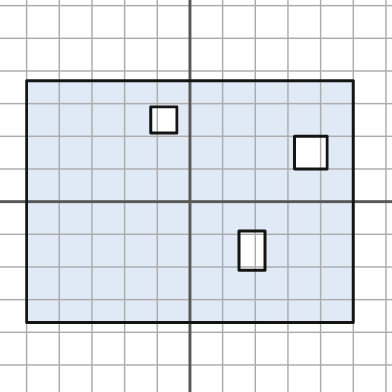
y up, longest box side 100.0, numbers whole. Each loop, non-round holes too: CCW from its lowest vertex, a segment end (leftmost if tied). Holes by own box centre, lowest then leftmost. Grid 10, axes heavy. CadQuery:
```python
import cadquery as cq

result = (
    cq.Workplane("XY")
    .moveTo(-50.0, -37.0)
    .lineTo(50.0, -37.0)
    .lineTo(50.0, 37.0)
    .lineTo(-50.0, 37.0)
    .close()
    .moveTo(15.0, -21.0)
    .lineTo(23.0, -21.0)
    .lineTo(23.0, -9.0)
    .lineTo(15.0, -9.0)
    .close()
    .moveTo(32.0, 10.0)
    .lineTo(42.0, 10.0)
    .lineTo(42.0, 20.0)
    .lineTo(32.0, 20.0)
    .close()
    .moveTo(-12.0, 21.0)
    .lineTo(-4.0, 21.0)
    .lineTo(-4.0, 29.0)
    .lineTo(-12.0, 29.0)
    .close()
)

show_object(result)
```